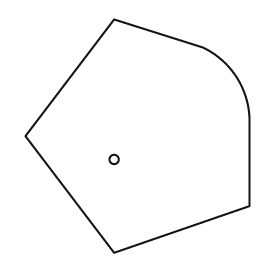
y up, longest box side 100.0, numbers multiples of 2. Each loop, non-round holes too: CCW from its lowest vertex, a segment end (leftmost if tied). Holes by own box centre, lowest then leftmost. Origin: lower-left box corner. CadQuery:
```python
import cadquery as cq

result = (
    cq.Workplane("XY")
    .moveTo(38.0, 0.0)
    .lineTo(96.0, 20.0)
    .lineTo(96.0, 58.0)
    .threePointArc((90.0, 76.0), (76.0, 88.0))
    .lineTo(38.0, 100.0)
    .lineTo(0.0, 50.0)
    .close()
    .moveTo(38.0, 40.0)
    .circle(2.0)
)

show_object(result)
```